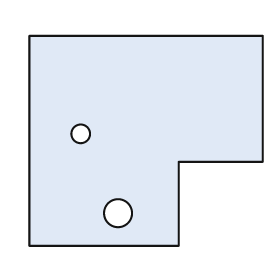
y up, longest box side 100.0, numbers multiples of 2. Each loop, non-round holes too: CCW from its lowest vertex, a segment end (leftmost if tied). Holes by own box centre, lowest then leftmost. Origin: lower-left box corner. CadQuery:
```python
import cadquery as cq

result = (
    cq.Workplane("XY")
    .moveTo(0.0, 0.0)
    .lineTo(64.0, 0.0)
    .lineTo(64.0, 36.0)
    .lineTo(100.0, 36.0)
    .lineTo(100.0, 90.0)
    .lineTo(0.0, 90.0)
    .close()
    .moveTo(38.0, 14.0)
    .circle(6.0)
    .moveTo(22.0, 48.0)
    .circle(4.0)
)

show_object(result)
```